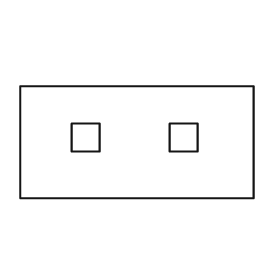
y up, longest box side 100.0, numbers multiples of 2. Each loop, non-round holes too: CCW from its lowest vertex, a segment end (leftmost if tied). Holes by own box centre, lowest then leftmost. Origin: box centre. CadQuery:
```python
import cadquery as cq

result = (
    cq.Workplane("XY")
    .moveTo(-50.0, -24.0)
    .lineTo(50.0, -24.0)
    .lineTo(50.0, 24.0)
    .lineTo(-50.0, 24.0)
    .close()
    .moveTo(-28.0, -4.0)
    .lineTo(-16.0, -4.0)
    .lineTo(-16.0, 8.0)
    .lineTo(-28.0, 8.0)
    .close()
    .moveTo(14.0, -4.0)
    .lineTo(26.0, -4.0)
    .lineTo(26.0, 8.0)
    .lineTo(14.0, 8.0)
    .close()
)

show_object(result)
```